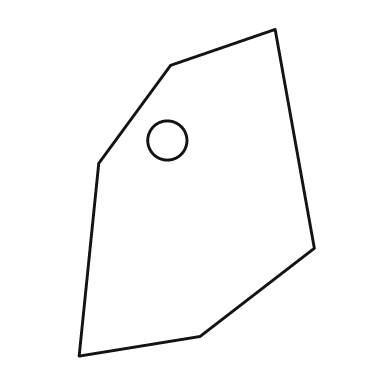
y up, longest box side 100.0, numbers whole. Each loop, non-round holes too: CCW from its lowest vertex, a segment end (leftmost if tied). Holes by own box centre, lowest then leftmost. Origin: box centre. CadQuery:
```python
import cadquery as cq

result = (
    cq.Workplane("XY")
    .moveTo(-36.0, -50.0)
    .lineTo(1.0, -44.0)
    .lineTo(36.0, -17.0)
    .lineTo(24.0, 50.0)
    .lineTo(-8.0, 39.0)
    .lineTo(-30.0, 9.0)
    .close()
    .moveTo(-9.0, 16.0)
    .circle(6.0)
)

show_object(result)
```